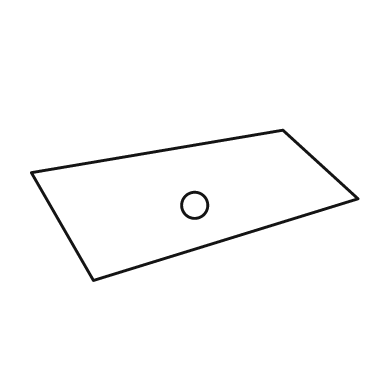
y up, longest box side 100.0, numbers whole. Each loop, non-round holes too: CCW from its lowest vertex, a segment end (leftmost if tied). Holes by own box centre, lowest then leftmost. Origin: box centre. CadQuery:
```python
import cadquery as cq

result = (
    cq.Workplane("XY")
    .moveTo(-31.0, -23.0)
    .lineTo(50.0, 2.0)
    .lineTo(27.0, 23.0)
    .lineTo(-50.0, 10.0)
    .close()
    .moveTo(0.0, 0.0)
    .circle(4.0)
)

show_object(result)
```